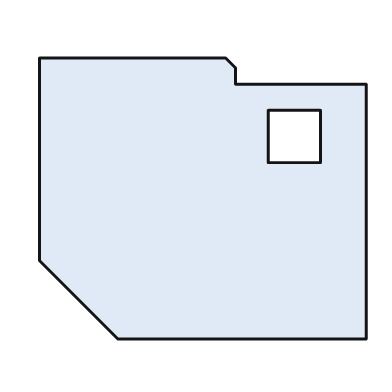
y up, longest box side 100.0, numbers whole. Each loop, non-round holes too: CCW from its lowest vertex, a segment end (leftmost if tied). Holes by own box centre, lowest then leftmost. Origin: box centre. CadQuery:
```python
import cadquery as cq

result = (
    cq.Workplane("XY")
    .moveTo(-26.0, -43.0)
    .lineTo(50.0, -43.0)
    .lineTo(50.0, 35.0)
    .lineTo(10.0, 35.0)
    .lineTo(10.0, 40.0)
    .lineTo(7.0, 43.0)
    .lineTo(-50.0, 43.0)
    .lineTo(-50.0, -19.0)
    .close()
    .moveTo(20.0, 11.0)
    .lineTo(36.0, 11.0)
    .lineTo(36.0, 27.0)
    .lineTo(20.0, 27.0)
    .close()
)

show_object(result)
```